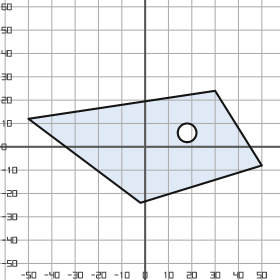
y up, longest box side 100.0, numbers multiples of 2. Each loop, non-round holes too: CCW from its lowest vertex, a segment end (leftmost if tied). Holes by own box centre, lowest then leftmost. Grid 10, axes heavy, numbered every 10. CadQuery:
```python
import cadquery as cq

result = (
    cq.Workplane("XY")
    .moveTo(-2.0, -24.0)
    .lineTo(50.0, -8.0)
    .lineTo(30.0, 24.0)
    .lineTo(-50.0, 12.0)
    .close()
    .moveTo(18.0, 6.0)
    .circle(4.0)
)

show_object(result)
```